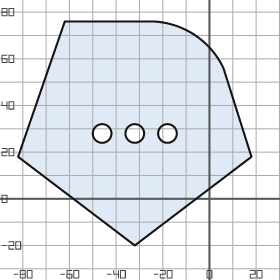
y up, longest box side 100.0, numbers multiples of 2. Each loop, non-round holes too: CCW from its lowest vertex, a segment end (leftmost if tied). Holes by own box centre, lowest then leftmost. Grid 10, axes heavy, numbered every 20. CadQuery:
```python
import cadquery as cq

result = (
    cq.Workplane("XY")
    .moveTo(-32.0, -20.0)
    .lineTo(18.0, 18.0)
    .lineTo(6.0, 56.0)
    .threePointArc((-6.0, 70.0), (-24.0, 76.0))
    .lineTo(-62.0, 76.0)
    .lineTo(-82.0, 18.0)
    .close()
    .moveTo(-46.0, 28.0)
    .circle(4.0)
    .moveTo(-32.0, 28.0)
    .circle(4.0)
    .moveTo(-18.0, 28.0)
    .circle(4.0)
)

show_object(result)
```